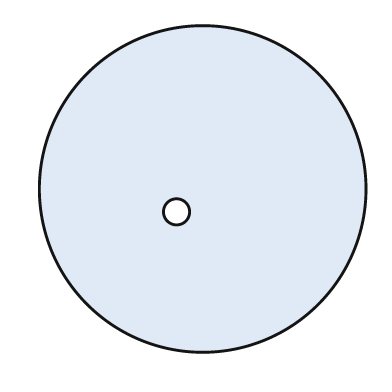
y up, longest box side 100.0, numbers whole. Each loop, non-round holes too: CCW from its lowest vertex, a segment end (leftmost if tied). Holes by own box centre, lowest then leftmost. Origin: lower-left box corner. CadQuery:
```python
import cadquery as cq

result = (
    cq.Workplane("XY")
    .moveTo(50.0, 50.0)
    .circle(50.0)
    .moveTo(42.0, 43.0)
    .circle(4.0)
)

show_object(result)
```